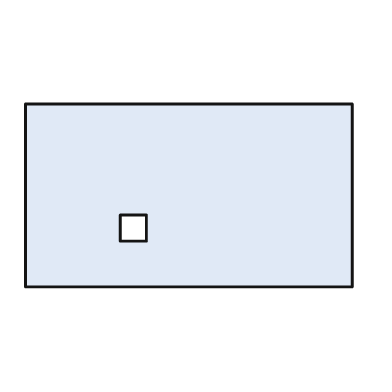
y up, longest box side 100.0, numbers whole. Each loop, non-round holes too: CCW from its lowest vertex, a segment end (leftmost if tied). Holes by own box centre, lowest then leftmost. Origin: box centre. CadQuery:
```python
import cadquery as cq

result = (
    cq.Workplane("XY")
    .moveTo(-50.0, -28.0)
    .lineTo(50.0, -28.0)
    .lineTo(50.0, 28.0)
    .lineTo(-50.0, 28.0)
    .close()
    .moveTo(-21.0, -14.0)
    .lineTo(-13.0, -14.0)
    .lineTo(-13.0, -6.0)
    .lineTo(-21.0, -6.0)
    .close()
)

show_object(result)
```